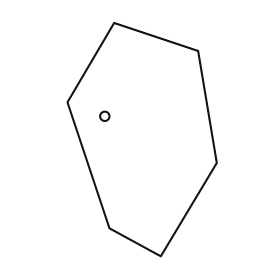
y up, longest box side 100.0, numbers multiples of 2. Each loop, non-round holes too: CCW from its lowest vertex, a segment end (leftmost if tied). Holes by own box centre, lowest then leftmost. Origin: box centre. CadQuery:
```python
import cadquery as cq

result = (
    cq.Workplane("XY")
    .moveTo(8.0, -50.0)
    .lineTo(32.0, -10.0)
    .lineTo(24.0, 38.0)
    .lineTo(-12.0, 50.0)
    .lineTo(-32.0, 16.0)
    .lineTo(-14.0, -38.0)
    .close()
    .moveTo(-16.0, 10.0)
    .circle(2.0)
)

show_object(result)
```